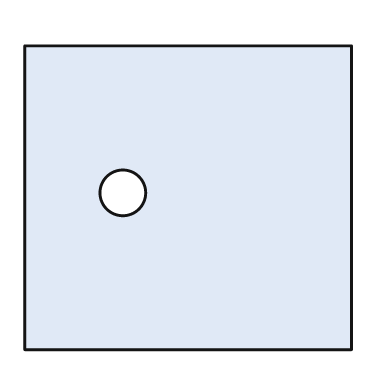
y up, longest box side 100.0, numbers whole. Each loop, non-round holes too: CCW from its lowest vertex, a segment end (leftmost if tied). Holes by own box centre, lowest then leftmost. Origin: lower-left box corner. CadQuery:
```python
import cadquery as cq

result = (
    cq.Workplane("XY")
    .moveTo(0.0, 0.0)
    .lineTo(100.0, 0.0)
    .lineTo(100.0, 93.0)
    .lineTo(0.0, 93.0)
    .close()
    .moveTo(30.0, 48.0)
    .circle(7.0)
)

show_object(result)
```